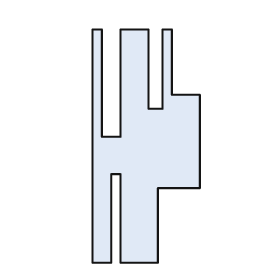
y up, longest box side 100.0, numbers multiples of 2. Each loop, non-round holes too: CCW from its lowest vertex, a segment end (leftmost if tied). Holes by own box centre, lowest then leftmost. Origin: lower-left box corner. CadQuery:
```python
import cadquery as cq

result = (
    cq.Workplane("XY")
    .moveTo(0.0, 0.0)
    .lineTo(8.0, 0.0)
    .lineTo(8.0, 38.0)
    .lineTo(12.0, 38.0)
    .lineTo(12.0, 0.0)
    .lineTo(28.0, 0.0)
    .lineTo(28.0, 32.0)
    .lineTo(46.0, 32.0)
    .lineTo(46.0, 72.0)
    .lineTo(34.0, 72.0)
    .lineTo(34.0, 100.0)
    .lineTo(30.0, 100.0)
    .lineTo(30.0, 66.0)
    .lineTo(24.0, 66.0)
    .lineTo(24.0, 100.0)
    .lineTo(12.0, 100.0)
    .lineTo(12.0, 54.0)
    .lineTo(4.0, 54.0)
    .lineTo(4.0, 100.0)
    .lineTo(0.0, 100.0)
    .close()
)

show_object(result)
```